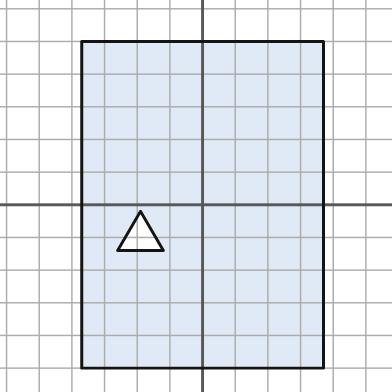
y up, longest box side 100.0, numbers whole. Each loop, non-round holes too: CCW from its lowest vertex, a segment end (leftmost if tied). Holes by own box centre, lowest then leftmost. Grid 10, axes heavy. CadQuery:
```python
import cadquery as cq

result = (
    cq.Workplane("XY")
    .moveTo(-37.0, -50.0)
    .lineTo(37.0, -50.0)
    .lineTo(37.0, 50.0)
    .lineTo(-37.0, 50.0)
    .close()
    .moveTo(-26.0, -14.0)
    .lineTo(-12.0, -14.0)
    .lineTo(-19.0, -2.0)
    .close()
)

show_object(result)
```